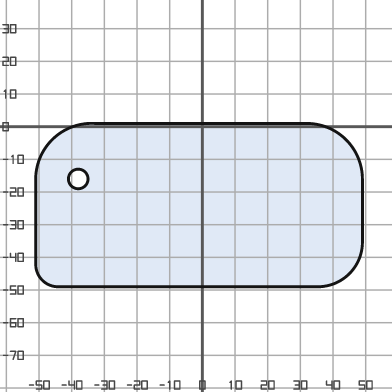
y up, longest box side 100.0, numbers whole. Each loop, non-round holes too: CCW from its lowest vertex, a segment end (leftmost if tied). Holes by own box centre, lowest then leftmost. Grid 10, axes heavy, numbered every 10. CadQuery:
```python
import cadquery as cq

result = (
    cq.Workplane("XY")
    .moveTo(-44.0, -49.0)
    .lineTo(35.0, -49.0)
    .threePointArc((45.0, -45.0), (49.0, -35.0))
    .lineTo(49.0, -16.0)
    .threePointArc((44.0, -4.0), (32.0, 1.0))
    .lineTo(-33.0, 1.0)
    .threePointArc((-46.0, -4.0), (-51.0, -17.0))
    .lineTo(-51.0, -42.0)
    .threePointArc((-49.0, -47.0), (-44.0, -49.0))
    .close()
    .moveTo(-38.0, -16.0)
    .circle(3.0)
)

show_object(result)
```